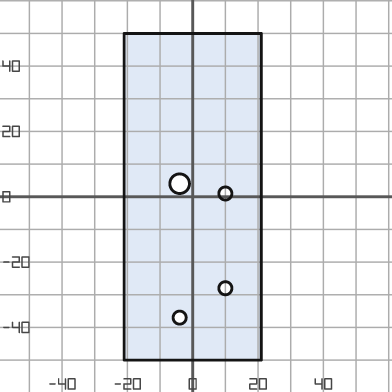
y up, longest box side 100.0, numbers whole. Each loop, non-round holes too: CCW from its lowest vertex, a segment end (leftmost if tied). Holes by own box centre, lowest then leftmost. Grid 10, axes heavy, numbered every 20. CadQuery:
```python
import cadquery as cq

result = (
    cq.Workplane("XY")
    .moveTo(-21.0, -50.0)
    .lineTo(21.0, -50.0)
    .lineTo(21.0, 50.0)
    .lineTo(-21.0, 50.0)
    .close()
    .moveTo(-4.0, -37.0)
    .circle(2.0)
    .moveTo(10.0, -28.0)
    .circle(2.0)
    .moveTo(10.0, 1.0)
    .circle(2.0)
    .moveTo(-4.0, 4.0)
    .circle(3.0)
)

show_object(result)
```